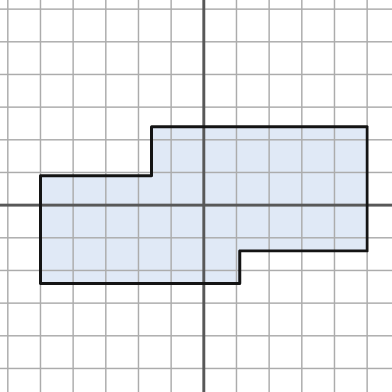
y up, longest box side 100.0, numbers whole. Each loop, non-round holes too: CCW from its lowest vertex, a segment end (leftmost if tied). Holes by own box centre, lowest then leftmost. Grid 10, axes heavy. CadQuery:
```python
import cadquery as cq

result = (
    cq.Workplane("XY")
    .moveTo(-50.0, -24.0)
    .lineTo(11.0, -24.0)
    .lineTo(11.0, -14.0)
    .lineTo(50.0, -14.0)
    .lineTo(50.0, 24.0)
    .lineTo(-16.0, 24.0)
    .lineTo(-16.0, 9.0)
    .lineTo(-50.0, 9.0)
    .close()
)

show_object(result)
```